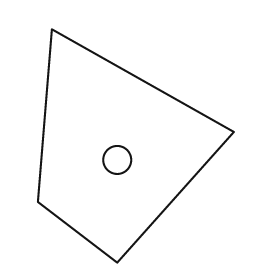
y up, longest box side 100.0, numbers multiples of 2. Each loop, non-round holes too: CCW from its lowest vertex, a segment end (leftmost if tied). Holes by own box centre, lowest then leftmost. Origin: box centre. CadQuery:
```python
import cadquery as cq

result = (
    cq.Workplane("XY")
    .moveTo(-8.0, -50.0)
    .lineTo(42.0, 6.0)
    .lineTo(-36.0, 50.0)
    .lineTo(-42.0, -24.0)
    .close()
    .moveTo(-8.0, -6.0)
    .circle(6.0)
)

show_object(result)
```